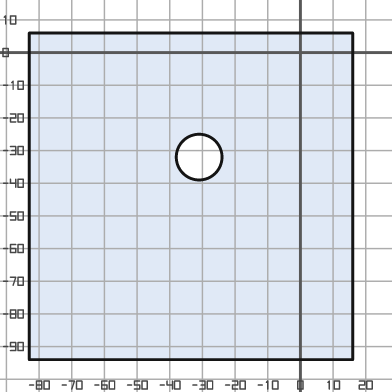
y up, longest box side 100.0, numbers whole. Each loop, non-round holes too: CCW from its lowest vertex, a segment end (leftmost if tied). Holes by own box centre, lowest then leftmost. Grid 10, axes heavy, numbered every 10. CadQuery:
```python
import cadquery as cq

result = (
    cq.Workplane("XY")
    .moveTo(-83.0, -94.0)
    .lineTo(16.0, -94.0)
    .lineTo(16.0, 6.0)
    .lineTo(-83.0, 6.0)
    .close()
    .moveTo(-31.0, -32.0)
    .circle(7.0)
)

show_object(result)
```